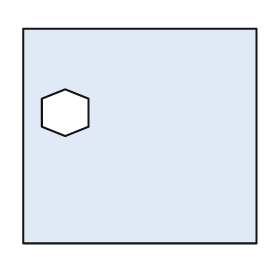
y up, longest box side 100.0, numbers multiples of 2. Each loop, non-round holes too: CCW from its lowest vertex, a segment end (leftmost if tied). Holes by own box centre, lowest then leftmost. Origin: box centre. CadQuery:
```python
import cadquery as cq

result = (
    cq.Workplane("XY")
    .moveTo(-50.0, -46.0)
    .lineTo(50.0, -46.0)
    .lineTo(50.0, 46.0)
    .lineTo(-50.0, 46.0)
    .close()
    .moveTo(-32.0, 0.0)
    .lineTo(-22.0, 4.0)
    .lineTo(-22.0, 16.0)
    .lineTo(-32.0, 20.0)
    .lineTo(-42.0, 16.0)
    .lineTo(-42.0, 4.0)
    .close()
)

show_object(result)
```